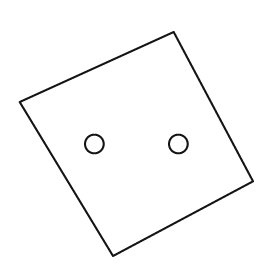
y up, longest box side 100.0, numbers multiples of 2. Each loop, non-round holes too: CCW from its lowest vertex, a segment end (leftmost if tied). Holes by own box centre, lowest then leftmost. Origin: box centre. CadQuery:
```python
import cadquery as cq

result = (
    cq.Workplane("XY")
    .moveTo(-10.0, -48.0)
    .lineTo(50.0, -16.0)
    .lineTo(16.0, 48.0)
    .lineTo(-50.0, 18.0)
    .close()
    .moveTo(-18.0, 0.0)
    .circle(4.0)
    .moveTo(18.0, 0.0)
    .circle(4.0)
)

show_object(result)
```